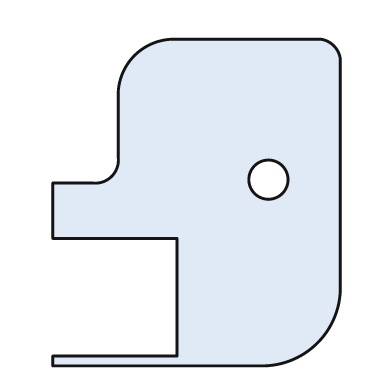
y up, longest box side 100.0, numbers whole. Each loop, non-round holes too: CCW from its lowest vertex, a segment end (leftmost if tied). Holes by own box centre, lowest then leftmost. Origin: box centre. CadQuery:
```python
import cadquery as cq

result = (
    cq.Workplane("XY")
    .moveTo(-44.0, -50.0)
    .lineTo(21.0, -50.0)
    .threePointArc((37.0, -43.0), (44.0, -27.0))
    .lineTo(44.0, 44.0)
    .threePointArc((42.0, 48.0), (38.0, 50.0))
    .lineTo(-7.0, 50.0)
    .threePointArc((-19.0, 45.0), (-24.0, 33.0))
    .lineTo(-24.0, 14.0)
    .threePointArc((-26.0, 8.0), (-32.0, 6.0))
    .lineTo(-44.0, 6.0)
    .lineTo(-44.0, -11.0)
    .lineTo(-6.0, -11.0)
    .lineTo(-6.0, -47.0)
    .lineTo(-44.0, -47.0)
    .close()
    .moveTo(22.0, 7.0)
    .circle(6.0)
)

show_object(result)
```